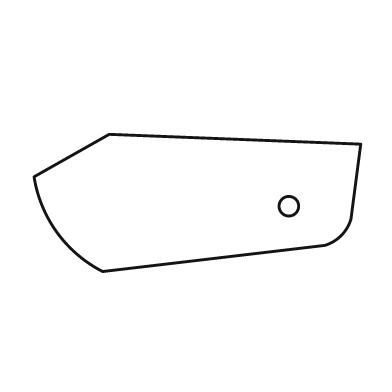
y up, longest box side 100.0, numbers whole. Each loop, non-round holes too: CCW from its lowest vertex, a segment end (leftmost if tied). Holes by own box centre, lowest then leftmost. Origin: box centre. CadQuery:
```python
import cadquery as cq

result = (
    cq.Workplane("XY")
    .moveTo(-29.0, -21.0)
    .lineTo(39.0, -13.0)
    .threePointArc((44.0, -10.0), (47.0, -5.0))
    .lineTo(50.0, 18.0)
    .lineTo(-27.0, 21.0)
    .lineTo(-50.0, 8.0)
    .threePointArc((-43.0, -9.0), (-29.0, -21.0))
    .close()
    .moveTo(28.0, -1.0)
    .circle(3.0)
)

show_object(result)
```